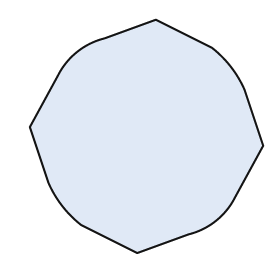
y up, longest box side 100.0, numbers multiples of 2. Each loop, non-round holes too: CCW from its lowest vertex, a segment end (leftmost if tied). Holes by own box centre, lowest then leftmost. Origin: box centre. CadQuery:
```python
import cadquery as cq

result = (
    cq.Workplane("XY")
    .moveTo(-4.0, -50.0)
    .lineTo(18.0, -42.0)
    .threePointArc((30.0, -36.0), (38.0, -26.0))
    .lineTo(50.0, -4.0)
    .lineTo(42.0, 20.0)
    .threePointArc((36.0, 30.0), (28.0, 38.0))
    .lineTo(4.0, 50.0)
    .lineTo(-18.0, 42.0)
    .threePointArc((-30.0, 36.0), (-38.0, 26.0))
    .lineTo(-50.0, 4.0)
    .lineTo(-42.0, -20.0)
    .threePointArc((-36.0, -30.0), (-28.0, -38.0))
    .close()
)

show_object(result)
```